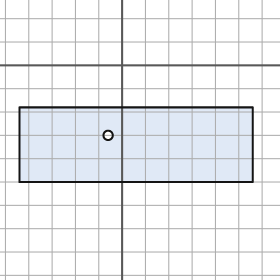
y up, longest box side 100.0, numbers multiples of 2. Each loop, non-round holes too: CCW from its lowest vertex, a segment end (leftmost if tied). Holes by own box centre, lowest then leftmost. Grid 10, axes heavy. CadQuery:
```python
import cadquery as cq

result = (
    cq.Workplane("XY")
    .moveTo(-44.0, -50.0)
    .lineTo(56.0, -50.0)
    .lineTo(56.0, -18.0)
    .lineTo(-44.0, -18.0)
    .close()
    .moveTo(-6.0, -30.0)
    .circle(2.0)
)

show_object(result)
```